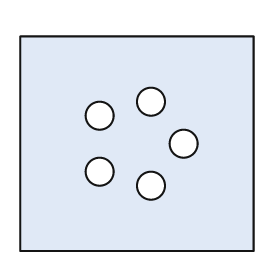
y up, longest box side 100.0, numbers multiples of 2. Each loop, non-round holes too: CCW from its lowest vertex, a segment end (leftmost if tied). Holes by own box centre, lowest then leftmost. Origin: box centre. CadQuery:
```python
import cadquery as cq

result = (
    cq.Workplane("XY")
    .moveTo(-50.0, -46.0)
    .lineTo(50.0, -46.0)
    .lineTo(50.0, 46.0)
    .lineTo(-50.0, 46.0)
    .close()
    .moveTo(6.0, -18.0)
    .circle(6.0)
    .moveTo(-16.0, -12.0)
    .circle(6.0)
    .moveTo(20.0, 0.0)
    .circle(6.0)
    .moveTo(-16.0, 12.0)
    .circle(6.0)
    .moveTo(6.0, 18.0)
    .circle(6.0)
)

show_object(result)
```